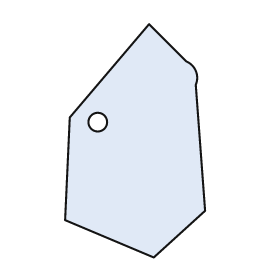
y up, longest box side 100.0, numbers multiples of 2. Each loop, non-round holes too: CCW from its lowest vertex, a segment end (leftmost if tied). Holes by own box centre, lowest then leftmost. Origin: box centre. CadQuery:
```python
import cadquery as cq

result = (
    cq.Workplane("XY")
    .moveTo(8.0, -50.0)
    .lineTo(30.0, -30.0)
    .lineTo(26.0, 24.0)
    .threePointArc((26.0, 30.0), (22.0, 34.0))
    .lineTo(6.0, 50.0)
    .lineTo(-28.0, 10.0)
    .lineTo(-30.0, -34.0)
    .close()
    .moveTo(-16.0, 8.0)
    .circle(4.0)
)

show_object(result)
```